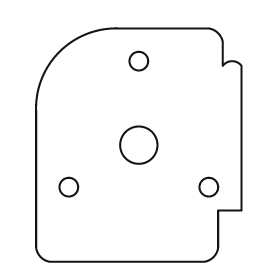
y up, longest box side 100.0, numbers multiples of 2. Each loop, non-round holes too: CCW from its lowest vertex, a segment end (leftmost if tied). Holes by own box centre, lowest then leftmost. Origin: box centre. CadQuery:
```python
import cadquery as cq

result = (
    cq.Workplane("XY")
    .moveTo(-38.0, -50.0)
    .lineTo(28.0, -50.0)
    .threePointArc((32.0, -48.0), (34.0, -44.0))
    .lineTo(34.0, -28.0)
    .lineTo(44.0, -28.0)
    .lineTo(44.0, 34.0)
    .threePointArc((40.0, 36.0), (36.0, 34.0))
    .lineTo(36.0, 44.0)
    .threePointArc((34.0, 48.0), (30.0, 50.0))
    .lineTo(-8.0, 50.0)
    .threePointArc((-34.0, 40.0), (-44.0, 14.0))
    .lineTo(-44.0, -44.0)
    .threePointArc((-42.0, -48.0), (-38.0, -50.0))
    .close()
    .moveTo(-30.0, -18.0)
    .circle(4.0)
    .moveTo(30.0, -18.0)
    .circle(4.0)
    .moveTo(0.0, 0.0)
    .circle(8.0)
    .moveTo(0.0, 36.0)
    .circle(4.0)
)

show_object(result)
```